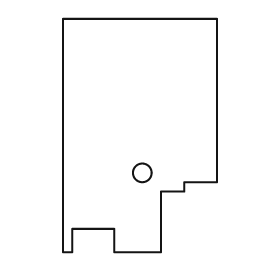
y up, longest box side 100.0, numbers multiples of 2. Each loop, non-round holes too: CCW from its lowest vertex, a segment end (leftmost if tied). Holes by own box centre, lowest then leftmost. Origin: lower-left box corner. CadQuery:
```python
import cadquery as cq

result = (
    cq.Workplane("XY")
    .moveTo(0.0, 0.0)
    .lineTo(4.0, 0.0)
    .lineTo(4.0, 10.0)
    .lineTo(22.0, 10.0)
    .lineTo(22.0, 0.0)
    .lineTo(42.0, 0.0)
    .lineTo(42.0, 26.0)
    .lineTo(52.0, 26.0)
    .lineTo(52.0, 30.0)
    .lineTo(66.0, 30.0)
    .lineTo(66.0, 100.0)
    .lineTo(0.0, 100.0)
    .close()
    .moveTo(34.0, 34.0)
    .circle(4.0)
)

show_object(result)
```